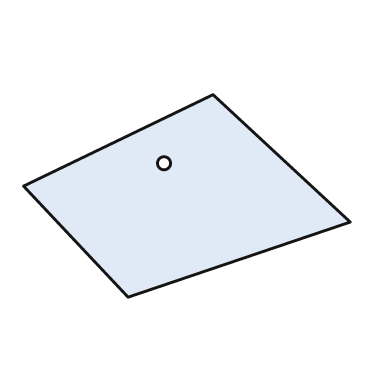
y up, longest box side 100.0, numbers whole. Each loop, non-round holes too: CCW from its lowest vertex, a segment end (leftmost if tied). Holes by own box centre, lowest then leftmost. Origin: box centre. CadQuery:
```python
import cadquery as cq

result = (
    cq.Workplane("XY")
    .moveTo(-18.0, -31.0)
    .lineTo(50.0, -8.0)
    .lineTo(8.0, 31.0)
    .lineTo(-50.0, 3.0)
    .close()
    .moveTo(-7.0, 10.0)
    .circle(2.0)
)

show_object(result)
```